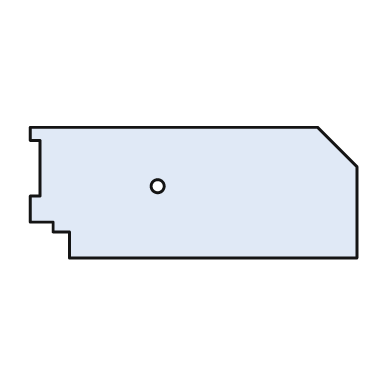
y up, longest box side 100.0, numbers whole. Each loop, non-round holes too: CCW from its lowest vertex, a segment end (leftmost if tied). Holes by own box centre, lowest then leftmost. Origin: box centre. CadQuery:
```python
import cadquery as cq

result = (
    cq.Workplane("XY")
    .moveTo(-38.0, -20.0)
    .lineTo(50.0, -20.0)
    .lineTo(50.0, 8.0)
    .lineTo(38.0, 20.0)
    .lineTo(-50.0, 20.0)
    .lineTo(-50.0, 16.0)
    .lineTo(-47.0, 16.0)
    .lineTo(-47.0, -1.0)
    .lineTo(-50.0, -1.0)
    .lineTo(-50.0, -9.0)
    .lineTo(-43.0, -9.0)
    .lineTo(-43.0, -12.0)
    .lineTo(-38.0, -12.0)
    .close()
    .moveTo(-11.0, 2.0)
    .circle(2.0)
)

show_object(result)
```